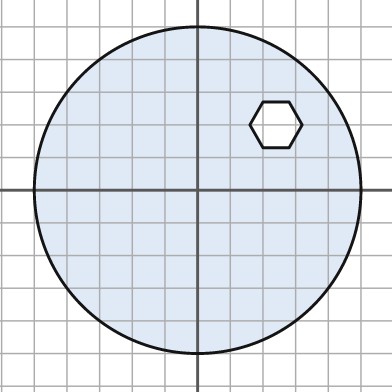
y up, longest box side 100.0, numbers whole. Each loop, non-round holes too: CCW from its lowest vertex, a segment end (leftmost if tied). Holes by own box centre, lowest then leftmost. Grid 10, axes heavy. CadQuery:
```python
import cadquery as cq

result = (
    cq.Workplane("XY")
    .moveTo(0.0, 0.0)
    .circle(50.0)
    .moveTo(20.0, 13.0)
    .lineTo(28.0, 13.0)
    .lineTo(32.0, 20.0)
    .lineTo(28.0, 27.0)
    .lineTo(20.0, 27.0)
    .lineTo(16.0, 20.0)
    .close()
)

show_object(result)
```